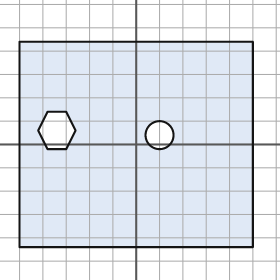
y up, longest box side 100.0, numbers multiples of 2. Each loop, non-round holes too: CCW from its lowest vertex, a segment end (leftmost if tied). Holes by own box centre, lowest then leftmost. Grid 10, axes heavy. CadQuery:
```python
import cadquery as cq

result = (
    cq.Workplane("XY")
    .moveTo(-50.0, -44.0)
    .lineTo(50.0, -44.0)
    .lineTo(50.0, 44.0)
    .lineTo(-50.0, 44.0)
    .close()
    .moveTo(10.0, 4.0)
    .circle(6.0)
    .moveTo(-38.0, -2.0)
    .lineTo(-30.0, -2.0)
    .lineTo(-26.0, 6.0)
    .lineTo(-30.0, 14.0)
    .lineTo(-38.0, 14.0)
    .lineTo(-42.0, 6.0)
    .close()
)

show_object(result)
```